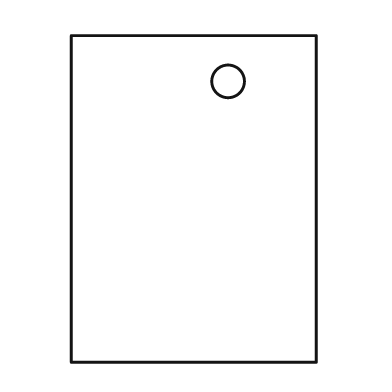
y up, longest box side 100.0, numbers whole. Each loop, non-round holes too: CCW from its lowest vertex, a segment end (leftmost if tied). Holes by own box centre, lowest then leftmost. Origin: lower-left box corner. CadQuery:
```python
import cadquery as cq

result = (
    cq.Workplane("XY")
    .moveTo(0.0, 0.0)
    .lineTo(75.0, 0.0)
    .lineTo(75.0, 100.0)
    .lineTo(0.0, 100.0)
    .close()
    .moveTo(48.0, 86.0)
    .circle(5.0)
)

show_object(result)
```